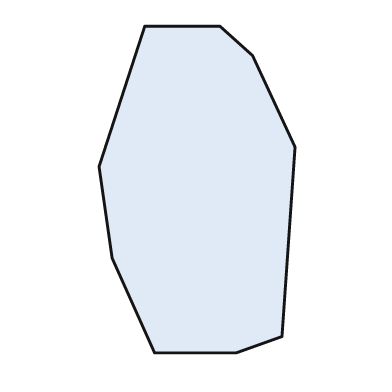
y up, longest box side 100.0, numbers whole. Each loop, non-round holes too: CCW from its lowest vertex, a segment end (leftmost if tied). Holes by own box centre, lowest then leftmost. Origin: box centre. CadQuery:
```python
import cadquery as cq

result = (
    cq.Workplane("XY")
    .moveTo(-13.0, -50.0)
    .lineTo(12.0, -50.0)
    .lineTo(26.0, -45.0)
    .lineTo(30.0, 13.0)
    .lineTo(17.0, 41.0)
    .lineTo(7.0, 50.0)
    .lineTo(-16.0, 50.0)
    .lineTo(-30.0, 7.0)
    .lineTo(-26.0, -21.0)
    .close()
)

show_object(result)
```